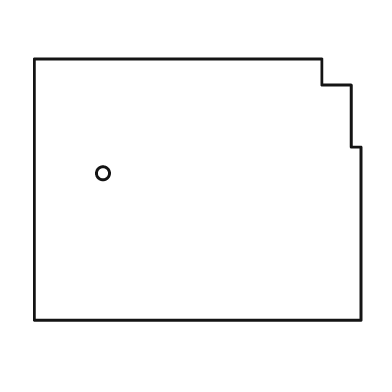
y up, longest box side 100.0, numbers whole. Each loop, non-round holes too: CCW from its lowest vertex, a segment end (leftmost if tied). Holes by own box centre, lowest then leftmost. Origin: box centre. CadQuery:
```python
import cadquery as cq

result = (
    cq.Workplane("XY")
    .moveTo(-50.0, -40.0)
    .lineTo(50.0, -40.0)
    .lineTo(50.0, 13.0)
    .lineTo(47.0, 13.0)
    .lineTo(47.0, 32.0)
    .lineTo(38.0, 32.0)
    .lineTo(38.0, 40.0)
    .lineTo(-50.0, 40.0)
    .close()
    .moveTo(-29.0, 5.0)
    .circle(2.0)
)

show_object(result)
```